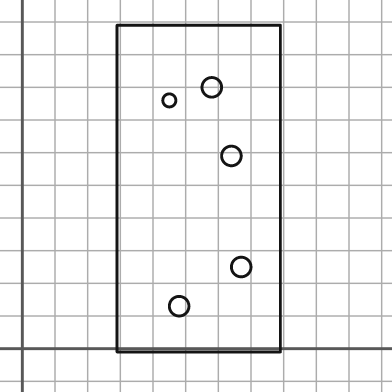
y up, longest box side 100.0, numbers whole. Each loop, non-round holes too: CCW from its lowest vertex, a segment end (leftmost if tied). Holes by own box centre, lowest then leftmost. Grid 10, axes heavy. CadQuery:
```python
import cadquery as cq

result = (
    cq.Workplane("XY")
    .moveTo(29.0, -1.0)
    .lineTo(79.0, -1.0)
    .lineTo(79.0, 99.0)
    .lineTo(29.0, 99.0)
    .close()
    .moveTo(48.0, 13.0)
    .circle(3.0)
    .moveTo(67.0, 25.0)
    .circle(3.0)
    .moveTo(64.0, 59.0)
    .circle(3.0)
    .moveTo(45.0, 76.0)
    .circle(2.0)
    .moveTo(58.0, 80.0)
    .circle(3.0)
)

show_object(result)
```